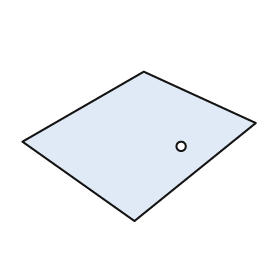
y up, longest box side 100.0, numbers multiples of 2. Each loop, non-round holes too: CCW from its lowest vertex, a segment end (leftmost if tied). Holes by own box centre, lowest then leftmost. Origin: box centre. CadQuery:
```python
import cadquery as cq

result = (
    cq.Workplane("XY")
    .moveTo(-2.0, -32.0)
    .lineTo(50.0, 10.0)
    .lineTo(2.0, 32.0)
    .lineTo(-50.0, 2.0)
    .close()
    .moveTo(18.0, 0.0)
    .circle(2.0)
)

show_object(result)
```